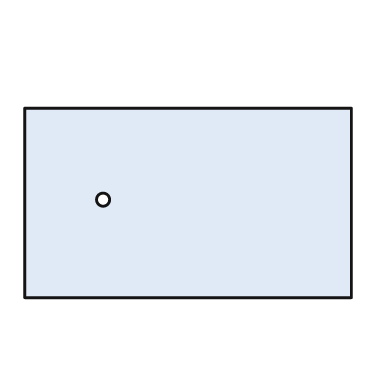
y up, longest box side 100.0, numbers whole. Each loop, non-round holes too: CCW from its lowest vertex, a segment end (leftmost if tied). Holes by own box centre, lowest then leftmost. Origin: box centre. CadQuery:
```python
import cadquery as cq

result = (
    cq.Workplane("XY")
    .moveTo(-50.0, -29.0)
    .lineTo(50.0, -29.0)
    .lineTo(50.0, 29.0)
    .lineTo(-50.0, 29.0)
    .close()
    .moveTo(-26.0, 1.0)
    .circle(2.0)
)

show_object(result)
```